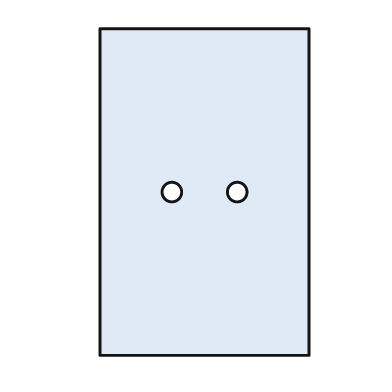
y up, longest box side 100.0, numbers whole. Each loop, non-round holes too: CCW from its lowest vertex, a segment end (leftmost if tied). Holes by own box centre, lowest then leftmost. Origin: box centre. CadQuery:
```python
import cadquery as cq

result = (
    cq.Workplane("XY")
    .moveTo(-32.0, -50.0)
    .lineTo(32.0, -50.0)
    .lineTo(32.0, 50.0)
    .lineTo(-32.0, 50.0)
    .close()
    .moveTo(-10.0, 0.0)
    .circle(3.0)
    .moveTo(10.0, 0.0)
    .circle(3.0)
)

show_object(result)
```